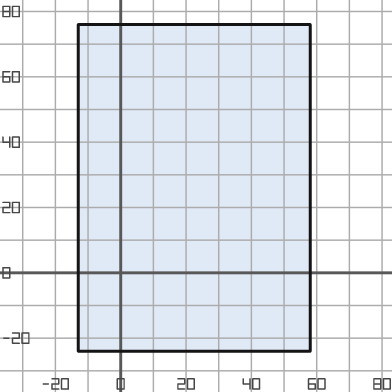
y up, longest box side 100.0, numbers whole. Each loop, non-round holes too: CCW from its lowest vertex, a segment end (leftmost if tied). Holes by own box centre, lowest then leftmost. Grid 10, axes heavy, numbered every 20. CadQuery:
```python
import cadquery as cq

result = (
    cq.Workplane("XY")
    .moveTo(-13.0, -24.0)
    .lineTo(58.0, -24.0)
    .lineTo(58.0, 76.0)
    .lineTo(-13.0, 76.0)
    .close()
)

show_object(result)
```